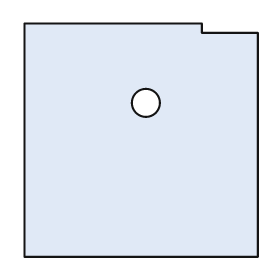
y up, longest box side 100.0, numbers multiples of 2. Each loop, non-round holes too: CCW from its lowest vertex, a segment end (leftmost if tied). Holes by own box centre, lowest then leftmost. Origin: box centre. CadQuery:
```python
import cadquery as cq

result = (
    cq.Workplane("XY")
    .moveTo(-50.0, -50.0)
    .lineTo(50.0, -50.0)
    .lineTo(50.0, 46.0)
    .lineTo(26.0, 46.0)
    .lineTo(26.0, 50.0)
    .lineTo(-50.0, 50.0)
    .close()
    .moveTo(2.0, 16.0)
    .circle(6.0)
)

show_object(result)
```